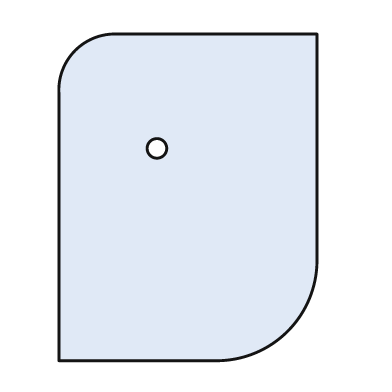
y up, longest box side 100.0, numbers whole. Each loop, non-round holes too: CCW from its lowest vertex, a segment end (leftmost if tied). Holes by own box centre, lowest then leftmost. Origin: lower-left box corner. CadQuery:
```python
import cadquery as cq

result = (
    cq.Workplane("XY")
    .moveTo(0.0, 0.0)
    .lineTo(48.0, 0.0)
    .threePointArc((70.0, 9.0), (79.0, 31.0))
    .lineTo(79.0, 100.0)
    .lineTo(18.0, 100.0)
    .threePointArc((5.0, 95.0), (0.0, 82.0))
    .close()
    .moveTo(30.0, 65.0)
    .circle(3.0)
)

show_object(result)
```